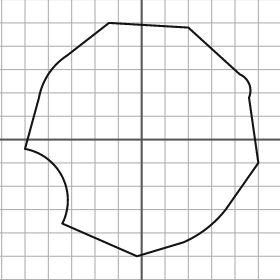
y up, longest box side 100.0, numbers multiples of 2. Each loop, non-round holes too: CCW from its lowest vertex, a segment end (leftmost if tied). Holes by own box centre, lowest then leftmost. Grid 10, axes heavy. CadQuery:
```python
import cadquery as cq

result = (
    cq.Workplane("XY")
    .moveTo(-2.0, -50.0)
    .lineTo(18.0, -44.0)
    .threePointArc((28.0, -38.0), (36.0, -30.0))
    .lineTo(50.0, -10.0)
    .lineTo(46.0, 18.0)
    .threePointArc((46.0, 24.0), (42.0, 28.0))
    .lineTo(20.0, 48.0)
    .lineTo(-14.0, 50.0)
    .lineTo(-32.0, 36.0)
    .threePointArc((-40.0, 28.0), (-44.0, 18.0))
    .lineTo(-50.0, -4.0)
    .threePointArc((-34.0, -16.0), (-34.0, -36.0))
    .close()
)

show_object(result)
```